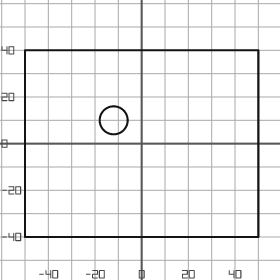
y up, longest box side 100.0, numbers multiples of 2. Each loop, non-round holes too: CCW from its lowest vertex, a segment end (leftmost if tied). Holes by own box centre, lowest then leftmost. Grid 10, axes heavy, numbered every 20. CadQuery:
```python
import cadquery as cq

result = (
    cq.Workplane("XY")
    .moveTo(-50.0, -40.0)
    .lineTo(50.0, -40.0)
    .lineTo(50.0, 40.0)
    .lineTo(-50.0, 40.0)
    .close()
    .moveTo(-12.0, 10.0)
    .circle(6.0)
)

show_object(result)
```